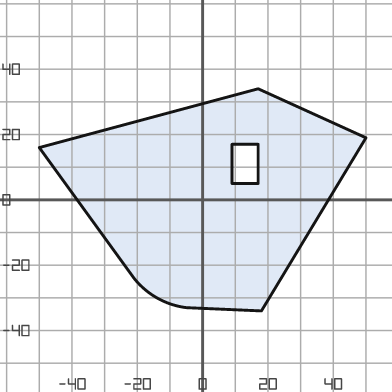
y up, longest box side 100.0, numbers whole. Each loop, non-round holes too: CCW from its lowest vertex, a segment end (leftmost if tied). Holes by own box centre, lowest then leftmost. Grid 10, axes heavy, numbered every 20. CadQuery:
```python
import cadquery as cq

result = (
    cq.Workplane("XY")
    .moveTo(18.0, -34.0)
    .lineTo(50.0, 19.0)
    .lineTo(17.0, 34.0)
    .lineTo(-50.0, 16.0)
    .lineTo(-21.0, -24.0)
    .threePointArc((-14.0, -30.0), (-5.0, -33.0))
    .close()
    .moveTo(9.0, 5.0)
    .lineTo(17.0, 5.0)
    .lineTo(17.0, 17.0)
    .lineTo(9.0, 17.0)
    .close()
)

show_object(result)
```